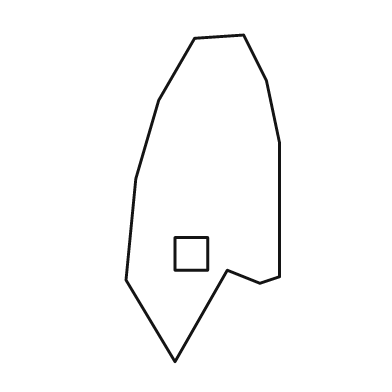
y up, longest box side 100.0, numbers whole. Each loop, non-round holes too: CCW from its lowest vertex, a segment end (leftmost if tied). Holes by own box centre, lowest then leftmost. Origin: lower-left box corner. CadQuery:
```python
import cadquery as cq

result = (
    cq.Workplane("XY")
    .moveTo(15.0, 0.0)
    .lineTo(31.0, 28.0)
    .lineTo(41.0, 24.0)
    .lineTo(47.0, 26.0)
    .lineTo(47.0, 67.0)
    .lineTo(43.0, 86.0)
    .lineTo(36.0, 100.0)
    .lineTo(21.0, 99.0)
    .lineTo(10.0, 80.0)
    .lineTo(3.0, 56.0)
    .lineTo(0.0, 25.0)
    .close()
    .moveTo(15.0, 28.0)
    .lineTo(25.0, 28.0)
    .lineTo(25.0, 38.0)
    .lineTo(15.0, 38.0)
    .close()
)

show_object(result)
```